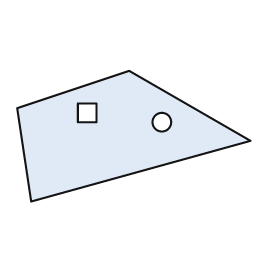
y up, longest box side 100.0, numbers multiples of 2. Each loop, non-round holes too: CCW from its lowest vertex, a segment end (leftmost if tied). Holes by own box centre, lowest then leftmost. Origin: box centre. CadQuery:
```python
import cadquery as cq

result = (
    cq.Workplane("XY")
    .moveTo(-44.0, -28.0)
    .lineTo(50.0, -2.0)
    .lineTo(-2.0, 28.0)
    .lineTo(-50.0, 12.0)
    .close()
    .moveTo(12.0, 6.0)
    .circle(4.0)
    .moveTo(-24.0, 6.0)
    .lineTo(-16.0, 6.0)
    .lineTo(-16.0, 14.0)
    .lineTo(-24.0, 14.0)
    .close()
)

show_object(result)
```